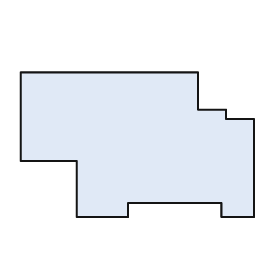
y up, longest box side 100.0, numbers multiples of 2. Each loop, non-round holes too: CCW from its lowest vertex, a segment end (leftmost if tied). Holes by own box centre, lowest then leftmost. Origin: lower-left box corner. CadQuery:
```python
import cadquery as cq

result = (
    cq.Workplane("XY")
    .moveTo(24.0, 0.0)
    .lineTo(46.0, 0.0)
    .lineTo(46.0, 6.0)
    .lineTo(86.0, 6.0)
    .lineTo(86.0, 0.0)
    .lineTo(100.0, 0.0)
    .lineTo(100.0, 42.0)
    .lineTo(88.0, 42.0)
    .lineTo(88.0, 46.0)
    .lineTo(76.0, 46.0)
    .lineTo(76.0, 62.0)
    .lineTo(0.0, 62.0)
    .lineTo(0.0, 24.0)
    .lineTo(24.0, 24.0)
    .close()
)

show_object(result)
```